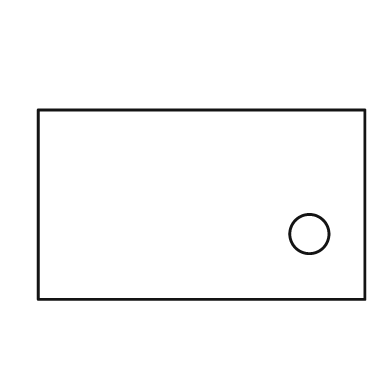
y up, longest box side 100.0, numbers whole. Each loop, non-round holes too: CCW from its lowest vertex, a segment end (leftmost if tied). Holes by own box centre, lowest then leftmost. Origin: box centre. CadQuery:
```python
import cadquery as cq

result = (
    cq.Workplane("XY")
    .moveTo(-50.0, -29.0)
    .lineTo(50.0, -29.0)
    .lineTo(50.0, 29.0)
    .lineTo(-50.0, 29.0)
    .close()
    .moveTo(33.0, -9.0)
    .circle(6.0)
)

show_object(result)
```